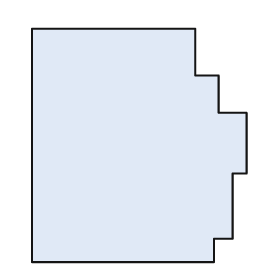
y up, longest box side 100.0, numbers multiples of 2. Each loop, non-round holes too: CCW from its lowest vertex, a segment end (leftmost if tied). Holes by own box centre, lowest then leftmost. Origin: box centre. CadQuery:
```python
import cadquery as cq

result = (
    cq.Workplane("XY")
    .moveTo(-46.0, -50.0)
    .lineTo(32.0, -50.0)
    .lineTo(32.0, -40.0)
    .lineTo(40.0, -40.0)
    .lineTo(40.0, -12.0)
    .lineTo(46.0, -12.0)
    .lineTo(46.0, 14.0)
    .lineTo(34.0, 14.0)
    .lineTo(34.0, 30.0)
    .lineTo(24.0, 30.0)
    .lineTo(24.0, 50.0)
    .lineTo(-46.0, 50.0)
    .close()
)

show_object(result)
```